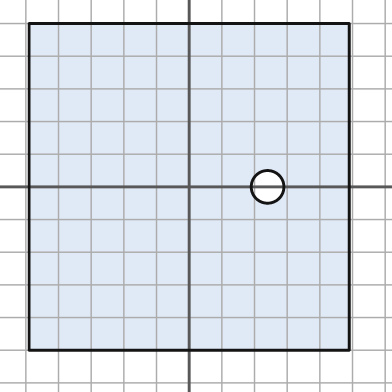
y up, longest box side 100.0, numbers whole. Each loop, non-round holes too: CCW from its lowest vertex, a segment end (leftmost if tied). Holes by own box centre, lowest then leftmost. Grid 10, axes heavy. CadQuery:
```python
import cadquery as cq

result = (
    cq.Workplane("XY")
    .moveTo(-49.0, -50.0)
    .lineTo(49.0, -50.0)
    .lineTo(49.0, 50.0)
    .lineTo(-49.0, 50.0)
    .close()
    .moveTo(24.0, 0.0)
    .circle(5.0)
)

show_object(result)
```